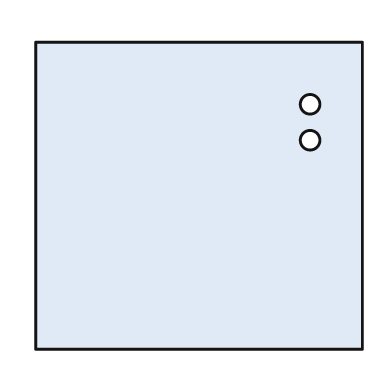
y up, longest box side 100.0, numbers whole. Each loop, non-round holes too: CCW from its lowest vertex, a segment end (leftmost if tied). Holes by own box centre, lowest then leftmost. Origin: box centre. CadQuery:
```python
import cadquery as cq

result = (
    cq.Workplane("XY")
    .moveTo(-50.0, -47.0)
    .lineTo(50.0, -47.0)
    .lineTo(50.0, 47.0)
    .lineTo(-50.0, 47.0)
    .close()
    .moveTo(34.0, 17.0)
    .circle(3.0)
    .moveTo(34.0, 28.0)
    .circle(3.0)
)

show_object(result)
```